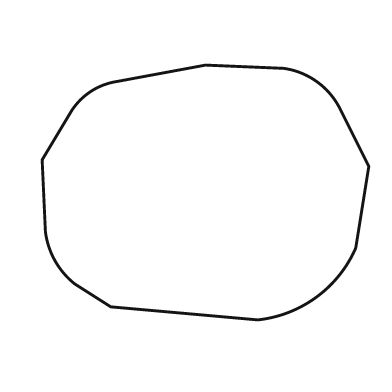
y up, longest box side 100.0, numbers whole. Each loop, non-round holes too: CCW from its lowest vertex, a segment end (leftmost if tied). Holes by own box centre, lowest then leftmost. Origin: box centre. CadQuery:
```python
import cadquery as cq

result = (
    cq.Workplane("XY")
    .moveTo(16.0, -39.0)
    .threePointArc((34.0, -32.0), (46.0, -17.0))
    .lineTo(50.0, 8.0)
    .lineTo(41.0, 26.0)
    .threePointArc((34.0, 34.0), (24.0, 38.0))
    .lineTo(0.0, 39.0)
    .lineTo(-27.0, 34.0)
    .threePointArc((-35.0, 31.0), (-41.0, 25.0))
    .lineTo(-50.0, 10.0)
    .lineTo(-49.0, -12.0)
    .threePointArc((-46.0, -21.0), (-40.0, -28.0))
    .lineTo(-29.0, -35.0)
    .close()
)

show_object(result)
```